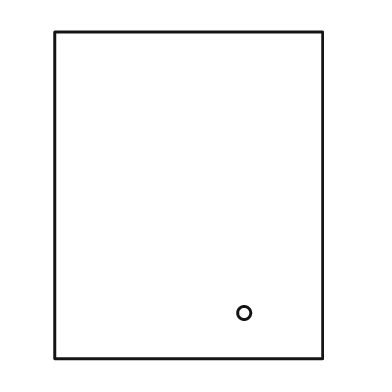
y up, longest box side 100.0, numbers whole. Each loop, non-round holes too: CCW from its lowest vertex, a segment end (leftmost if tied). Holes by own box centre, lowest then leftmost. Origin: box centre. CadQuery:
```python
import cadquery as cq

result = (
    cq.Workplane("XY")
    .moveTo(-41.0, -50.0)
    .lineTo(41.0, -50.0)
    .lineTo(41.0, 50.0)
    .lineTo(-41.0, 50.0)
    .close()
    .moveTo(17.0, -36.0)
    .circle(2.0)
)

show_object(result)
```